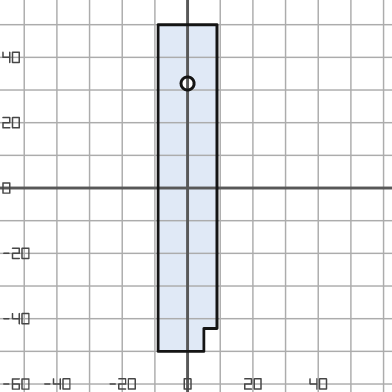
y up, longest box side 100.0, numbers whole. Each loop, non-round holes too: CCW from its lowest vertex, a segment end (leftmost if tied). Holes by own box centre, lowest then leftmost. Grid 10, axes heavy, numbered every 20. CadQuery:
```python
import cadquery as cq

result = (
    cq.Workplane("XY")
    .moveTo(-9.0, -50.0)
    .lineTo(5.0, -50.0)
    .lineTo(5.0, -43.0)
    .lineTo(9.0, -43.0)
    .lineTo(9.0, 50.0)
    .lineTo(-9.0, 50.0)
    .close()
    .moveTo(0.0, 32.0)
    .circle(2.0)
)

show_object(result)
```